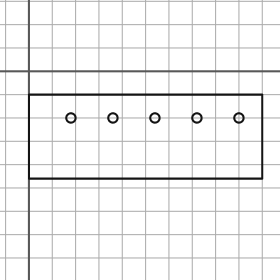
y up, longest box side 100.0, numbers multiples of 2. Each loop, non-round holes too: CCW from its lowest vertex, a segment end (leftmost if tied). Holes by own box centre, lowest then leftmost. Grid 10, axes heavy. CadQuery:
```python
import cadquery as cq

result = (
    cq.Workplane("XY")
    .moveTo(0.0, -46.0)
    .lineTo(100.0, -46.0)
    .lineTo(100.0, -10.0)
    .lineTo(0.0, -10.0)
    .close()
    .moveTo(18.0, -20.0)
    .circle(2.0)
    .moveTo(36.0, -20.0)
    .circle(2.0)
    .moveTo(54.0, -20.0)
    .circle(2.0)
    .moveTo(72.0, -20.0)
    .circle(2.0)
    .moveTo(90.0, -20.0)
    .circle(2.0)
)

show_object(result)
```